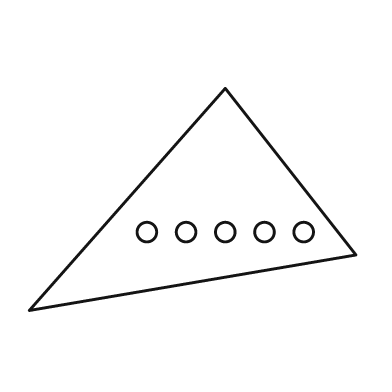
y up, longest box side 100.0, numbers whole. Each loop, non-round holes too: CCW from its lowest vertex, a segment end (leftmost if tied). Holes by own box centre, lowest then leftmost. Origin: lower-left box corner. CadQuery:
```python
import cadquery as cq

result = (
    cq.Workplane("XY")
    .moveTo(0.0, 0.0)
    .lineTo(100.0, 17.0)
    .lineTo(60.0, 68.0)
    .close()
    .moveTo(36.0, 24.0)
    .circle(3.0)
    .moveTo(48.0, 24.0)
    .circle(3.0)
    .moveTo(60.0, 24.0)
    .circle(3.0)
    .moveTo(72.0, 24.0)
    .circle(3.0)
    .moveTo(84.0, 24.0)
    .circle(3.0)
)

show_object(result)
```